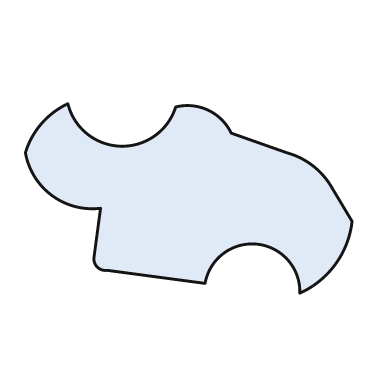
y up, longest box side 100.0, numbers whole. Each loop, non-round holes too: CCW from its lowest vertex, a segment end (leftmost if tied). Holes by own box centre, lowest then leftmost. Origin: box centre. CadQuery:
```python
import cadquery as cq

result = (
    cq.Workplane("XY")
    .moveTo(34.0, -29.0)
    .threePointArc((45.0, -20.0), (50.0, -7.0))
    .lineTo(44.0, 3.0)
    .threePointArc((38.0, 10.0), (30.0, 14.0))
    .lineTo(13.0, 20.0)
    .threePointArc((6.0, 27.0), (-4.0, 28.0))
    .threePointArc((-21.0, 16.0), (-37.0, 29.0))
    .threePointArc((-45.0, 23.0), (-50.0, 14.0))
    .threePointArc((-42.0, 1.0), (-27.0, -3.0))
    .lineTo(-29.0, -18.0)
    .threePointArc((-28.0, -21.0), (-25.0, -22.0))
    .lineTo(5.0, -26.0)
    .threePointArc((21.0, -14.0), (34.0, -29.0))
    .close()
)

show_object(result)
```